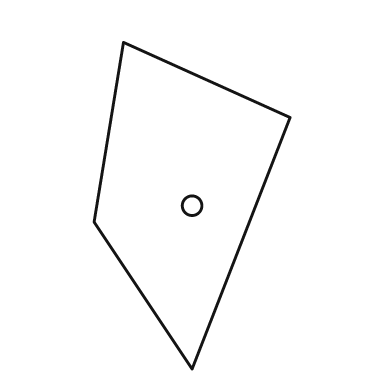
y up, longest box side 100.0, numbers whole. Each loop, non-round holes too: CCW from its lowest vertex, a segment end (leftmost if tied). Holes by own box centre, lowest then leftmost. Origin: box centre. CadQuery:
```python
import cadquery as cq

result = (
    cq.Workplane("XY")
    .moveTo(0.0, -50.0)
    .lineTo(30.0, 27.0)
    .lineTo(-21.0, 50.0)
    .lineTo(-30.0, -5.0)
    .close()
    .moveTo(0.0, 0.0)
    .circle(3.0)
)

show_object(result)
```